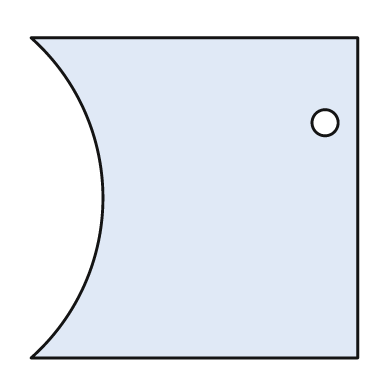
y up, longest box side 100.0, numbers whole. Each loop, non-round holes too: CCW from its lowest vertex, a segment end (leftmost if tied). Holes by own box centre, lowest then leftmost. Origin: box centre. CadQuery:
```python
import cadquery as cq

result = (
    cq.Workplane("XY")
    .moveTo(-50.0, -49.0)
    .lineTo(50.0, -49.0)
    .lineTo(50.0, 49.0)
    .lineTo(-50.0, 49.0)
    .threePointArc((-28.0, 0.0), (-50.0, -49.0))
    .close()
    .moveTo(40.0, 23.0)
    .circle(4.0)
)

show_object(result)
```